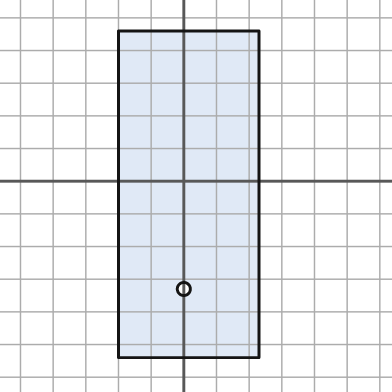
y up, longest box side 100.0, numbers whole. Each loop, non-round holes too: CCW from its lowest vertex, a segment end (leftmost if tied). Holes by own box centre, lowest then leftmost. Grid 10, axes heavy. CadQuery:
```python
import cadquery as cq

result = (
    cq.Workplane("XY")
    .moveTo(-20.0, -54.0)
    .lineTo(23.0, -54.0)
    .lineTo(23.0, 46.0)
    .lineTo(-20.0, 46.0)
    .close()
    .moveTo(0.0, -33.0)
    .circle(2.0)
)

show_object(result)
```